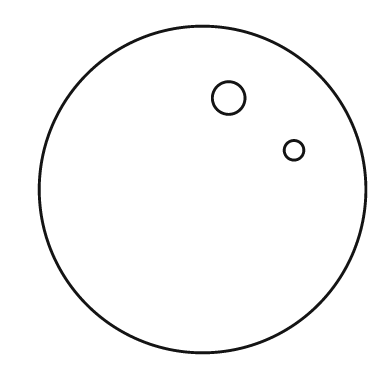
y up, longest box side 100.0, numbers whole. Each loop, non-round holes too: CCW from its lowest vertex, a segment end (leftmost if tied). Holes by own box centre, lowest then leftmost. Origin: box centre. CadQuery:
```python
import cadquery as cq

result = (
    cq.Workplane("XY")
    .moveTo(0.0, 0.0)
    .circle(50.0)
    .moveTo(28.0, 12.0)
    .circle(3.0)
    .moveTo(8.0, 28.0)
    .circle(5.0)
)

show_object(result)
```